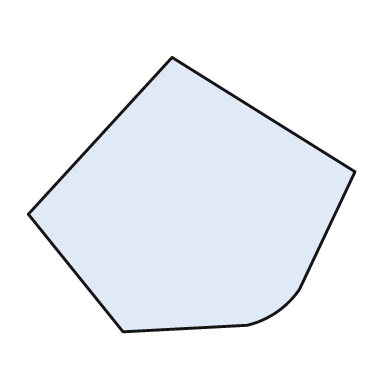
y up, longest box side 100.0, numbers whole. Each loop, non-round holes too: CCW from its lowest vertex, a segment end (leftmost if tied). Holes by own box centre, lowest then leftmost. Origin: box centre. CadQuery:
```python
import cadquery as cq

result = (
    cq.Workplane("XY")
    .moveTo(-21.0, -42.0)
    .lineTo(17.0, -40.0)
    .threePointArc((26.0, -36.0), (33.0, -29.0))
    .lineTo(50.0, 7.0)
    .lineTo(-6.0, 42.0)
    .lineTo(-50.0, -6.0)
    .close()
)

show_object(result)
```